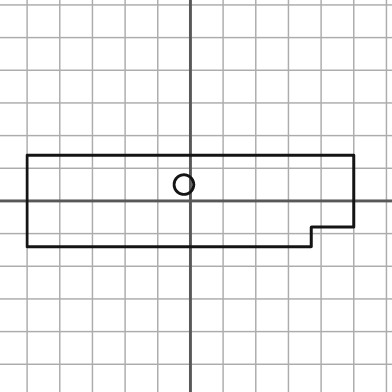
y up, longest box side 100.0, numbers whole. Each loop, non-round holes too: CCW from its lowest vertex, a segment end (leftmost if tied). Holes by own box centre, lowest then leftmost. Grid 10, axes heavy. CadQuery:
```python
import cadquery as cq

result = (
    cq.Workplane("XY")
    .moveTo(-50.0, -14.0)
    .lineTo(37.0, -14.0)
    .lineTo(37.0, -8.0)
    .lineTo(50.0, -8.0)
    .lineTo(50.0, 14.0)
    .lineTo(-50.0, 14.0)
    .close()
    .moveTo(-2.0, 5.0)
    .circle(3.0)
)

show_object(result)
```